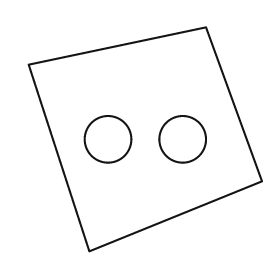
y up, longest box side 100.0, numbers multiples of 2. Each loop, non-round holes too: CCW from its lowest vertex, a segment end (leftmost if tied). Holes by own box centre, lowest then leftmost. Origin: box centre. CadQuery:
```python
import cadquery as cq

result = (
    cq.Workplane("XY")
    .moveTo(-24.0, -48.0)
    .lineTo(50.0, -18.0)
    .lineTo(26.0, 48.0)
    .lineTo(-50.0, 32.0)
    .close()
    .moveTo(-16.0, 0.0)
    .circle(10.0)
    .moveTo(16.0, 0.0)
    .circle(10.0)
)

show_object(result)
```